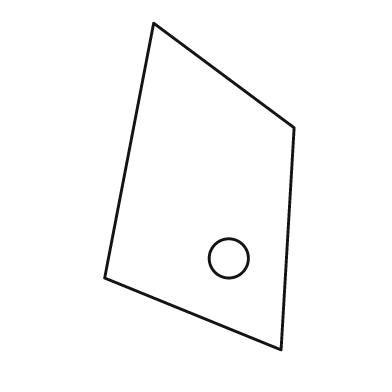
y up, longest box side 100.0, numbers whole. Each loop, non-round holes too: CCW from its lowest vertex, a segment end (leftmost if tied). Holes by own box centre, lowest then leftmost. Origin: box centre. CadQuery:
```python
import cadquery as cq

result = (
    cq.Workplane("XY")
    .moveTo(25.0, -50.0)
    .lineTo(29.0, 18.0)
    .lineTo(-14.0, 50.0)
    .lineTo(-29.0, -28.0)
    .close()
    .moveTo(9.0, -22.0)
    .circle(6.0)
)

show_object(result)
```